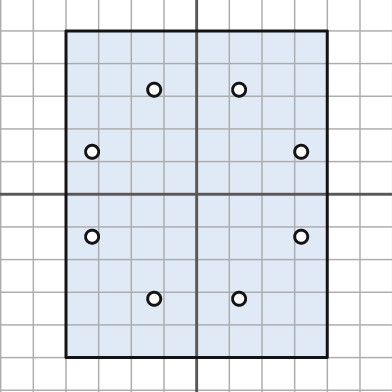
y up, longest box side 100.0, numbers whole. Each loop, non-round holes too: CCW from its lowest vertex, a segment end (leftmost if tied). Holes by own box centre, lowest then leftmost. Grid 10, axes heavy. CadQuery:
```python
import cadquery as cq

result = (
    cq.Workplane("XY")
    .moveTo(-40.0, -50.0)
    .lineTo(40.0, -50.0)
    .lineTo(40.0, 50.0)
    .lineTo(-40.0, 50.0)
    .close()
    .moveTo(-13.0, -32.0)
    .circle(2.0)
    .moveTo(13.0, -32.0)
    .circle(2.0)
    .moveTo(-32.0, -13.0)
    .circle(2.0)
    .moveTo(32.0, -13.0)
    .circle(2.0)
    .moveTo(-32.0, 13.0)
    .circle(2.0)
    .moveTo(32.0, 13.0)
    .circle(2.0)
    .moveTo(-13.0, 32.0)
    .circle(2.0)
    .moveTo(13.0, 32.0)
    .circle(2.0)
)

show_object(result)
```